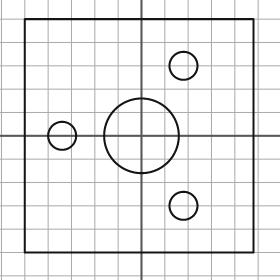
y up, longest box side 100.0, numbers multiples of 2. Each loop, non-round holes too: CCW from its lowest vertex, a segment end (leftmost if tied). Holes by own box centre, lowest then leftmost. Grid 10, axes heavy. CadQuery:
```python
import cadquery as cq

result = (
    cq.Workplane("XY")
    .moveTo(-50.0, -50.0)
    .lineTo(48.0, -50.0)
    .lineTo(48.0, 50.0)
    .lineTo(-50.0, 50.0)
    .close()
    .moveTo(18.0, -30.0)
    .circle(6.0)
    .moveTo(-34.0, 0.0)
    .circle(6.0)
    .moveTo(0.0, 0.0)
    .circle(16.0)
    .moveTo(18.0, 30.0)
    .circle(6.0)
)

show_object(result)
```